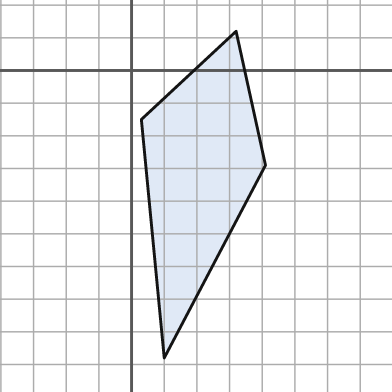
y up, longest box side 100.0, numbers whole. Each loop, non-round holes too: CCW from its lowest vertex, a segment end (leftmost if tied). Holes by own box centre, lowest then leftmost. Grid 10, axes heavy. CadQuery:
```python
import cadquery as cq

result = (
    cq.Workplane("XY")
    .moveTo(10.0, -88.0)
    .lineTo(41.0, -29.0)
    .lineTo(32.0, 12.0)
    .lineTo(3.0, -15.0)
    .close()
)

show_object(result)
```